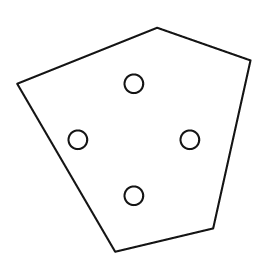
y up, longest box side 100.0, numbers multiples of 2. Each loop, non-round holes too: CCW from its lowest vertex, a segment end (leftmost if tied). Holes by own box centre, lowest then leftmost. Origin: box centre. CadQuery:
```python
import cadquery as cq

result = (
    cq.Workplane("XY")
    .moveTo(-8.0, -48.0)
    .lineTo(34.0, -38.0)
    .lineTo(50.0, 34.0)
    .lineTo(10.0, 48.0)
    .lineTo(-50.0, 24.0)
    .close()
    .moveTo(0.0, -24.0)
    .circle(4.0)
    .moveTo(-24.0, 0.0)
    .circle(4.0)
    .moveTo(24.0, 0.0)
    .circle(4.0)
    .moveTo(0.0, 24.0)
    .circle(4.0)
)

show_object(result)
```